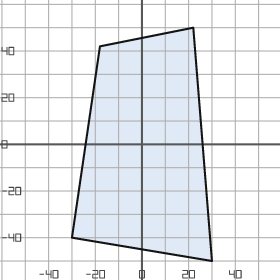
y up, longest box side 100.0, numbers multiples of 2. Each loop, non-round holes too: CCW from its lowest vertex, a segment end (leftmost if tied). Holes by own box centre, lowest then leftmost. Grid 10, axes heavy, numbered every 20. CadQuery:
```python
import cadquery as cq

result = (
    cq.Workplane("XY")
    .moveTo(30.0, -50.0)
    .lineTo(22.0, 50.0)
    .lineTo(-18.0, 42.0)
    .lineTo(-30.0, -40.0)
    .close()
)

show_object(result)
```